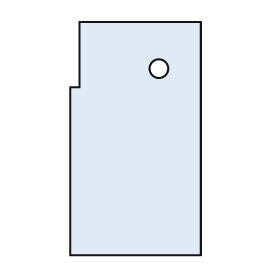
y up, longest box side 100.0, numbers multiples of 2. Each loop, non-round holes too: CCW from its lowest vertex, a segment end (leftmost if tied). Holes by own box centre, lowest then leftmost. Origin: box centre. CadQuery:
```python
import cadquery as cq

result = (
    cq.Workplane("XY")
    .moveTo(-28.0, -50.0)
    .lineTo(28.0, -50.0)
    .lineTo(28.0, 50.0)
    .lineTo(-24.0, 50.0)
    .lineTo(-24.0, 22.0)
    .lineTo(-28.0, 22.0)
    .close()
    .moveTo(10.0, 30.0)
    .circle(4.0)
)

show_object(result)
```